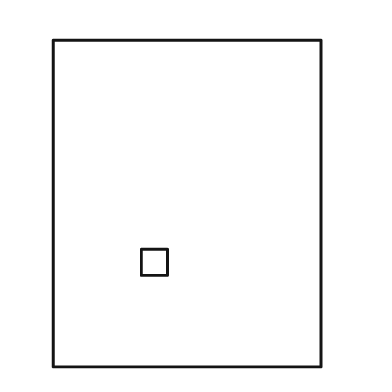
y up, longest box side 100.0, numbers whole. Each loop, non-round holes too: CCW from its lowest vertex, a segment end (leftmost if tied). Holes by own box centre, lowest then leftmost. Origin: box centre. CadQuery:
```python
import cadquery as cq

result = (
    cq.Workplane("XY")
    .moveTo(-41.0, -50.0)
    .lineTo(41.0, -50.0)
    .lineTo(41.0, 50.0)
    .lineTo(-41.0, 50.0)
    .close()
    .moveTo(-14.0, -22.0)
    .lineTo(-6.0, -22.0)
    .lineTo(-6.0, -14.0)
    .lineTo(-14.0, -14.0)
    .close()
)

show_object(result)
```